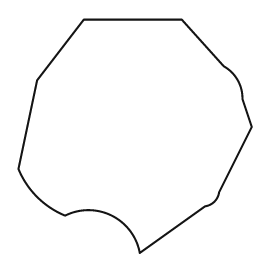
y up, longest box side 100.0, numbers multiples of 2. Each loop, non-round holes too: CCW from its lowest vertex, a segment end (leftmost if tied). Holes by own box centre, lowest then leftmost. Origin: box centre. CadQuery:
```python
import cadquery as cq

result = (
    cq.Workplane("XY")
    .moveTo(2.0, -50.0)
    .lineTo(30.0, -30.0)
    .threePointArc((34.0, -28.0), (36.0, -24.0))
    .lineTo(50.0, 4.0)
    .lineTo(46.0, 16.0)
    .threePointArc((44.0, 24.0), (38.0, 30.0))
    .lineTo(20.0, 50.0)
    .lineTo(-22.0, 50.0)
    .lineTo(-42.0, 24.0)
    .lineTo(-50.0, -14.0)
    .threePointArc((-42.0, -26.0), (-30.0, -34.0))
    .threePointArc((-10.0, -34.0), (2.0, -50.0))
    .close()
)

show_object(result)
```